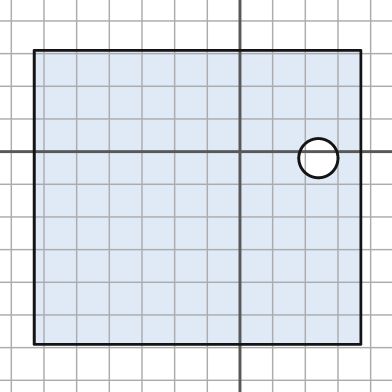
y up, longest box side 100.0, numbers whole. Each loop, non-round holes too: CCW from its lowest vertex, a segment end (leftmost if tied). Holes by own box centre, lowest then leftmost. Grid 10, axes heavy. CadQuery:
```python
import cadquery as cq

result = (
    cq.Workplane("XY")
    .moveTo(-63.0, -59.0)
    .lineTo(37.0, -59.0)
    .lineTo(37.0, 31.0)
    .lineTo(-63.0, 31.0)
    .close()
    .moveTo(24.0, -2.0)
    .circle(6.0)
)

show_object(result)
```